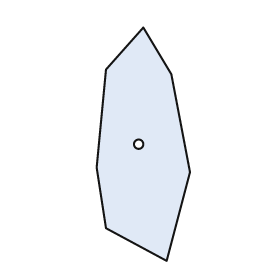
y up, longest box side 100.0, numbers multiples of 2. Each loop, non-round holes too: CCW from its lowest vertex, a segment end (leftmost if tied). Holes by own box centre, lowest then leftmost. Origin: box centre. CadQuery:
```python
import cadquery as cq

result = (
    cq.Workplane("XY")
    .moveTo(10.0, -50.0)
    .lineTo(20.0, -12.0)
    .lineTo(12.0, 30.0)
    .lineTo(0.0, 50.0)
    .lineTo(-16.0, 32.0)
    .lineTo(-20.0, -10.0)
    .lineTo(-16.0, -36.0)
    .close()
    .moveTo(-2.0, 0.0)
    .circle(2.0)
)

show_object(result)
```